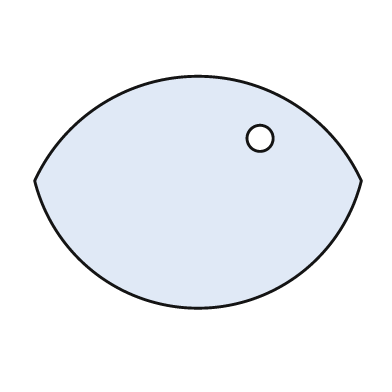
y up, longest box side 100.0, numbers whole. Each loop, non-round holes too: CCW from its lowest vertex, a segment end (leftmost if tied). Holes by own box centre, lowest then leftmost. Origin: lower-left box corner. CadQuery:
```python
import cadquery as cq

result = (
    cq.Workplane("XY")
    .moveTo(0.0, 39.0)
    .threePointArc((50.0, 0.0), (100.0, 39.0))
    .threePointArc((50.0, 71.0), (0.0, 39.0))
    .close()
    .moveTo(69.0, 52.0)
    .circle(4.0)
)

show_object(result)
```